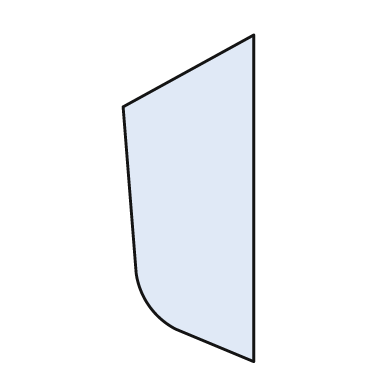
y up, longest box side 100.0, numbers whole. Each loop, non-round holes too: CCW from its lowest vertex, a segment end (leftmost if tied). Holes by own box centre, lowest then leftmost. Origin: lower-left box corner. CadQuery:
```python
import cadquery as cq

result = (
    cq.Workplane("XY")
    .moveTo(40.0, 0.0)
    .lineTo(40.0, 100.0)
    .lineTo(0.0, 78.0)
    .lineTo(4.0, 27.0)
    .threePointArc((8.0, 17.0), (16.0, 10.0))
    .close()
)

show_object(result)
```